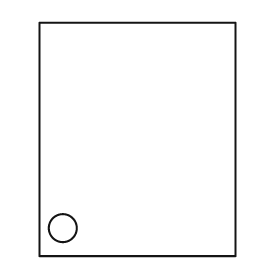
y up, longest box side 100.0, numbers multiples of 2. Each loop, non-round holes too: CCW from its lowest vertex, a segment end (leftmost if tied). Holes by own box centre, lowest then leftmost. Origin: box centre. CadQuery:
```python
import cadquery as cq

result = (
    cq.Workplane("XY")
    .moveTo(-42.0, -50.0)
    .lineTo(42.0, -50.0)
    .lineTo(42.0, 50.0)
    .lineTo(-42.0, 50.0)
    .close()
    .moveTo(-32.0, -38.0)
    .circle(6.0)
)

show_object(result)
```